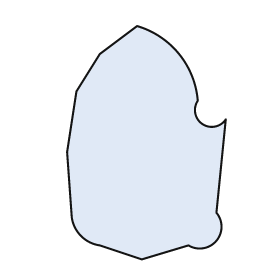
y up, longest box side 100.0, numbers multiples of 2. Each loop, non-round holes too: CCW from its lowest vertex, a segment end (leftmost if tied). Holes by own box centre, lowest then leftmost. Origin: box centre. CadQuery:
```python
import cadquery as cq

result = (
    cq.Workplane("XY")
    .moveTo(-2.0, -50.0)
    .lineTo(18.0, -44.0)
    .threePointArc((30.0, -42.0), (30.0, -30.0))
    .lineTo(34.0, 10.0)
    .threePointArc((24.0, 8.0), (22.0, 18.0))
    .threePointArc((14.0, 38.0), (-4.0, 50.0))
    .lineTo(-20.0, 38.0)
    .lineTo(-30.0, 22.0)
    .lineTo(-34.0, -4.0)
    .lineTo(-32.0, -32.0)
    .threePointArc((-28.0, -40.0), (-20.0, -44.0))
    .close()
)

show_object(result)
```